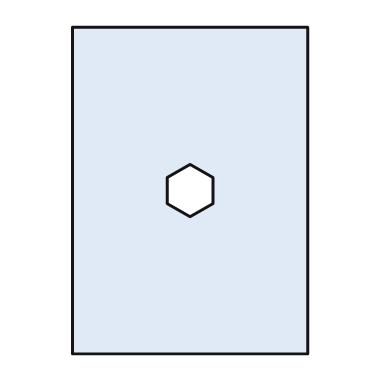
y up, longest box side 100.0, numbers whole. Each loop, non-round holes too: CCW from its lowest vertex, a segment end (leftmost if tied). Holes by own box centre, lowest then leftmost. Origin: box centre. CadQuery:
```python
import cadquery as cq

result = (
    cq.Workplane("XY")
    .moveTo(-36.0, -50.0)
    .lineTo(36.0, -50.0)
    .lineTo(36.0, 50.0)
    .lineTo(-36.0, 50.0)
    .close()
    .moveTo(0.0, -8.0)
    .lineTo(7.0, -4.0)
    .lineTo(7.0, 4.0)
    .lineTo(0.0, 8.0)
    .lineTo(-7.0, 4.0)
    .lineTo(-7.0, -4.0)
    .close()
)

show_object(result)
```